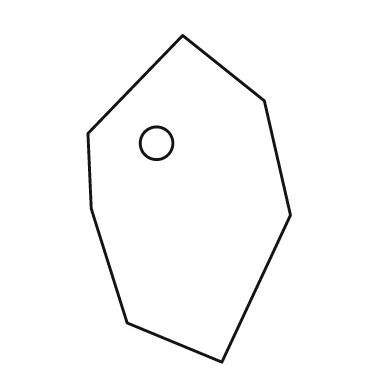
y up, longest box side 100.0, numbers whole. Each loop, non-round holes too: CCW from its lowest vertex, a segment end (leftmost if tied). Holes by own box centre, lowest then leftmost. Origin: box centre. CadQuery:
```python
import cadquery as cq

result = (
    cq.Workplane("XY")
    .moveTo(10.0, -50.0)
    .lineTo(31.0, -5.0)
    .lineTo(23.0, 30.0)
    .lineTo(-2.0, 50.0)
    .lineTo(-31.0, 20.0)
    .lineTo(-30.0, -3.0)
    .lineTo(-19.0, -38.0)
    .close()
    .moveTo(-10.0, 17.0)
    .circle(5.0)
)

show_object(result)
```